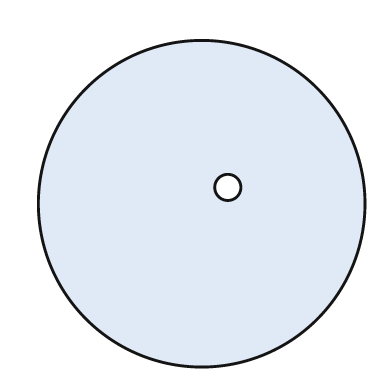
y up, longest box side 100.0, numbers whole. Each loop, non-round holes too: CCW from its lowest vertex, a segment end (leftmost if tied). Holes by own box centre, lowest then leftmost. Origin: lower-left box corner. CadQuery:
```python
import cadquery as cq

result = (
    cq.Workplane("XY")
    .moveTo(50.0, 50.0)
    .circle(50.0)
    .moveTo(58.0, 55.0)
    .circle(4.0)
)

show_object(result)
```